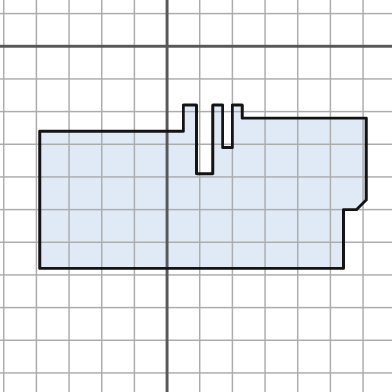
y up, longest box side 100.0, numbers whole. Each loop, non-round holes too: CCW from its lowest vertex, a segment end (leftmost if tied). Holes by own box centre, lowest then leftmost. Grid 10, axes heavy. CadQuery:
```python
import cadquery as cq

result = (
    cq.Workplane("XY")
    .moveTo(-39.0, -68.0)
    .lineTo(54.0, -68.0)
    .lineTo(54.0, -50.0)
    .lineTo(58.0, -50.0)
    .lineTo(61.0, -47.0)
    .lineTo(61.0, -22.0)
    .lineTo(23.0, -22.0)
    .lineTo(23.0, -18.0)
    .lineTo(20.0, -18.0)
    .lineTo(20.0, -31.0)
    .lineTo(17.0, -31.0)
    .lineTo(17.0, -18.0)
    .lineTo(14.0, -18.0)
    .lineTo(14.0, -39.0)
    .lineTo(9.0, -39.0)
    .lineTo(9.0, -18.0)
    .lineTo(5.0, -18.0)
    .lineTo(5.0, -26.0)
    .lineTo(-39.0, -26.0)
    .close()
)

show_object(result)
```